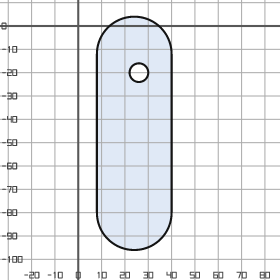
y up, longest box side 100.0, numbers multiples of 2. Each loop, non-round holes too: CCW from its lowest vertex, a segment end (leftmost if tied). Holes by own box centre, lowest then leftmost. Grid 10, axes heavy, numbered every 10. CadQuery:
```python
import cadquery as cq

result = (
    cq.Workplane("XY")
    .moveTo(8.0, -80.0)
    .threePointArc((24.0, -96.0), (40.0, -80.0))
    .lineTo(40.0, -12.0)
    .threePointArc((24.0, 4.0), (8.0, -12.0))
    .close()
    .moveTo(26.0, -20.0)
    .circle(4.0)
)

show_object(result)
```